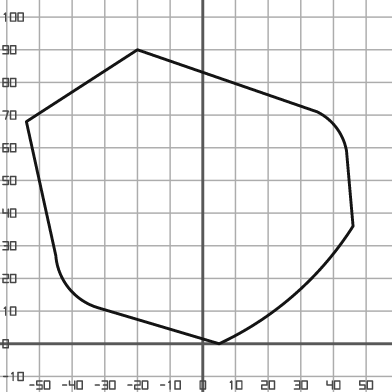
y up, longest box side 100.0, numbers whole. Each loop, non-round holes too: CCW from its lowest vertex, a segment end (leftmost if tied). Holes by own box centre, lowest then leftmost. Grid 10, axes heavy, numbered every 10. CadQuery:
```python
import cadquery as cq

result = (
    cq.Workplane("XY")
    .moveTo(5.0, 0.0)
    .threePointArc((28.0, 15.0), (46.0, 36.0))
    .lineTo(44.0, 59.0)
    .threePointArc((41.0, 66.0), (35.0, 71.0))
    .lineTo(-20.0, 90.0)
    .lineTo(-54.0, 68.0)
    .lineTo(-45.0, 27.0)
    .threePointArc((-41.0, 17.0), (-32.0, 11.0))
    .close()
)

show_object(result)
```